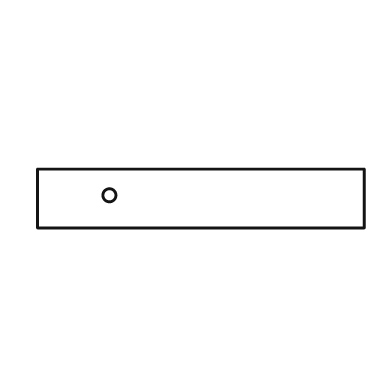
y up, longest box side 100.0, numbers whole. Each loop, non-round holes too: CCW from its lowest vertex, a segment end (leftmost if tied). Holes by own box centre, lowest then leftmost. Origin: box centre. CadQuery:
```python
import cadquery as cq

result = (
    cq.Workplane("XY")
    .moveTo(-50.0, -9.0)
    .lineTo(50.0, -9.0)
    .lineTo(50.0, 9.0)
    .lineTo(-50.0, 9.0)
    .close()
    .moveTo(-28.0, 1.0)
    .circle(2.0)
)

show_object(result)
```